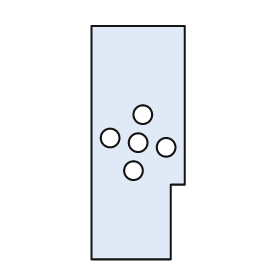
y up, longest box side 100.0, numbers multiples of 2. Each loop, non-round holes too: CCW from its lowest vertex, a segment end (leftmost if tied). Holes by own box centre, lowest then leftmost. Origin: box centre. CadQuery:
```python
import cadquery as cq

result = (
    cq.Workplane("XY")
    .moveTo(-20.0, -50.0)
    .lineTo(14.0, -50.0)
    .lineTo(14.0, -18.0)
    .lineTo(20.0, -18.0)
    .lineTo(20.0, 50.0)
    .lineTo(-20.0, 50.0)
    .close()
    .moveTo(-2.0, -12.0)
    .circle(4.0)
    .moveTo(12.0, -2.0)
    .circle(4.0)
    .moveTo(0.0, 0.0)
    .circle(4.0)
    .moveTo(-12.0, 2.0)
    .circle(4.0)
    .moveTo(2.0, 12.0)
    .circle(4.0)
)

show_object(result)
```